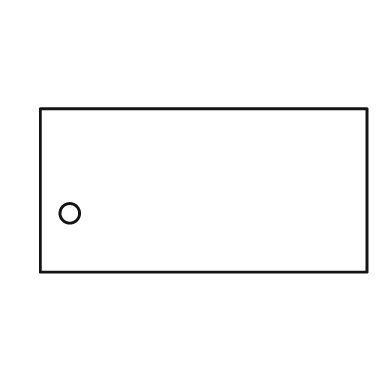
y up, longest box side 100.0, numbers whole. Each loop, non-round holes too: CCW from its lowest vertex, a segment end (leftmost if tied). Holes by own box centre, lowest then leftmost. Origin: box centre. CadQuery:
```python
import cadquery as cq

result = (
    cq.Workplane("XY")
    .moveTo(-50.0, -25.0)
    .lineTo(50.0, -25.0)
    .lineTo(50.0, 25.0)
    .lineTo(-50.0, 25.0)
    .close()
    .moveTo(-41.0, -7.0)
    .circle(3.0)
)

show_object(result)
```